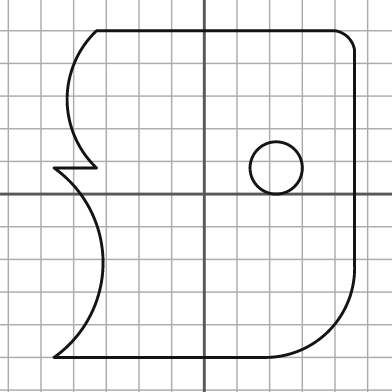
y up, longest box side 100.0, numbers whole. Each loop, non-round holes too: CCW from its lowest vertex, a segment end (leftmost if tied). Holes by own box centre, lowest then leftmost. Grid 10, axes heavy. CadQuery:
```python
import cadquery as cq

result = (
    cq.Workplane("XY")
    .moveTo(-46.0, -50.0)
    .lineTo(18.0, -50.0)
    .threePointArc((38.0, -42.0), (46.0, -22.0))
    .lineTo(46.0, 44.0)
    .threePointArc((44.0, 48.0), (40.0, 50.0))
    .lineTo(-33.0, 50.0)
    .threePointArc((-42.0, 29.0), (-33.0, 8.0))
    .lineTo(-46.0, 8.0)
    .threePointArc((-31.0, -21.0), (-46.0, -50.0))
    .close()
    .moveTo(22.0, 8.0)
    .circle(8.0)
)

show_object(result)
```